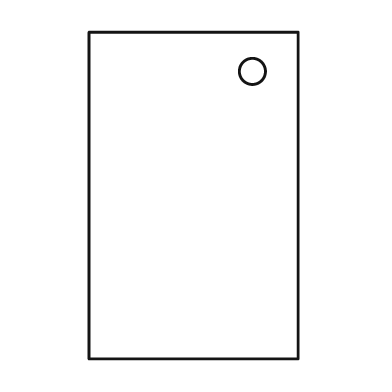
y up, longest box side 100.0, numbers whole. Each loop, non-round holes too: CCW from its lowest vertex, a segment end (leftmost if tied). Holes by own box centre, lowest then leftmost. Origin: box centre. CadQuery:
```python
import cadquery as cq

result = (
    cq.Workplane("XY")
    .moveTo(-32.0, -50.0)
    .lineTo(32.0, -50.0)
    .lineTo(32.0, 50.0)
    .lineTo(-32.0, 50.0)
    .close()
    .moveTo(18.0, 38.0)
    .circle(4.0)
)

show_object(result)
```